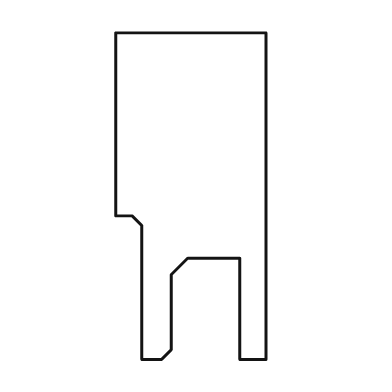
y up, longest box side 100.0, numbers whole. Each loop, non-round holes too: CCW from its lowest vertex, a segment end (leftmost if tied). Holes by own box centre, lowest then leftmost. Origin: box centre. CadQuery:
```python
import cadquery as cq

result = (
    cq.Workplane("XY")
    .moveTo(-15.0, -50.0)
    .lineTo(-9.0, -50.0)
    .lineTo(-6.0, -47.0)
    .lineTo(-6.0, -24.0)
    .lineTo(-1.0, -19.0)
    .lineTo(15.0, -19.0)
    .lineTo(15.0, -50.0)
    .lineTo(23.0, -50.0)
    .lineTo(23.0, 50.0)
    .lineTo(-23.0, 50.0)
    .lineTo(-23.0, -6.0)
    .lineTo(-18.0, -6.0)
    .lineTo(-15.0, -9.0)
    .close()
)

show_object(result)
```